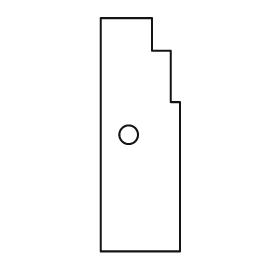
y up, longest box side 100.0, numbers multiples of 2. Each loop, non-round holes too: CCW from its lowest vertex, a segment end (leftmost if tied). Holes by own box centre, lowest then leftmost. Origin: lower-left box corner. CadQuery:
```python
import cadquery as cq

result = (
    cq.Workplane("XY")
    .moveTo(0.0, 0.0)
    .lineTo(34.0, 0.0)
    .lineTo(34.0, 64.0)
    .lineTo(30.0, 64.0)
    .lineTo(30.0, 86.0)
    .lineTo(22.0, 86.0)
    .lineTo(22.0, 100.0)
    .lineTo(0.0, 100.0)
    .close()
    .moveTo(12.0, 50.0)
    .circle(4.0)
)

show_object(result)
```